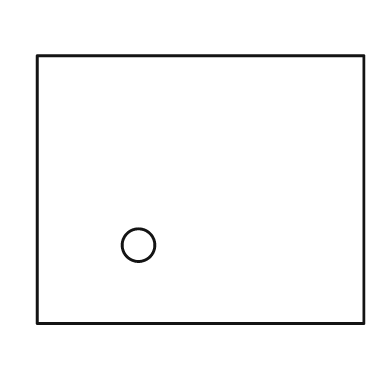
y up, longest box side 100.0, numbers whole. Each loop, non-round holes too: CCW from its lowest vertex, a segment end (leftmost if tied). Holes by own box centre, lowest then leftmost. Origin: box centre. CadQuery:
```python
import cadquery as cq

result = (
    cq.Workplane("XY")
    .moveTo(-50.0, -41.0)
    .lineTo(50.0, -41.0)
    .lineTo(50.0, 41.0)
    .lineTo(-50.0, 41.0)
    .close()
    .moveTo(-19.0, -17.0)
    .circle(5.0)
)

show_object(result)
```